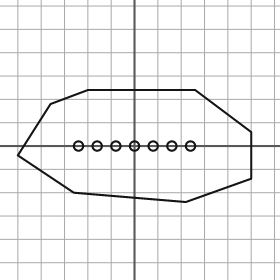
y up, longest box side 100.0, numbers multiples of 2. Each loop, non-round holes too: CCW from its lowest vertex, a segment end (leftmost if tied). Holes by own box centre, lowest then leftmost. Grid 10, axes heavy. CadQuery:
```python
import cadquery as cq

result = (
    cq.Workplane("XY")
    .moveTo(22.0, -24.0)
    .lineTo(50.0, -14.0)
    .lineTo(50.0, 6.0)
    .lineTo(26.0, 24.0)
    .lineTo(-20.0, 24.0)
    .lineTo(-36.0, 18.0)
    .lineTo(-50.0, -4.0)
    .lineTo(-26.0, -20.0)
    .close()
    .moveTo(-24.0, 0.0)
    .circle(2.0)
    .moveTo(-16.0, 0.0)
    .circle(2.0)
    .moveTo(-8.0, 0.0)
    .circle(2.0)
    .moveTo(0.0, 0.0)
    .circle(2.0)
    .moveTo(8.0, 0.0)
    .circle(2.0)
    .moveTo(16.0, 0.0)
    .circle(2.0)
    .moveTo(24.0, 0.0)
    .circle(2.0)
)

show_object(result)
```